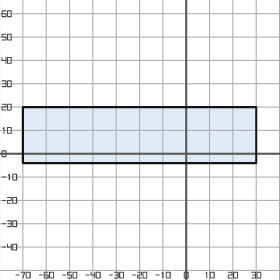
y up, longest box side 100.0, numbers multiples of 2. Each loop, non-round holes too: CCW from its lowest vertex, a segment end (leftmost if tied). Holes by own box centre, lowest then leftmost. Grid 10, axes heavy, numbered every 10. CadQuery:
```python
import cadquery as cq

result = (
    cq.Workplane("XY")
    .moveTo(-70.0, -4.0)
    .lineTo(30.0, -4.0)
    .lineTo(30.0, 20.0)
    .lineTo(-70.0, 20.0)
    .close()
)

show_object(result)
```